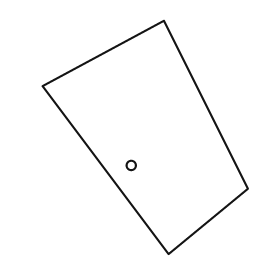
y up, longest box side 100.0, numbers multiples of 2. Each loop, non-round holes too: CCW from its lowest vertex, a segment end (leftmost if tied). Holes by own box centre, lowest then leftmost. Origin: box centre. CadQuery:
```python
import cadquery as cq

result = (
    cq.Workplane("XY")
    .moveTo(10.0, -50.0)
    .lineTo(44.0, -22.0)
    .lineTo(8.0, 50.0)
    .lineTo(-44.0, 22.0)
    .close()
    .moveTo(-6.0, -12.0)
    .circle(2.0)
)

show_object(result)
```